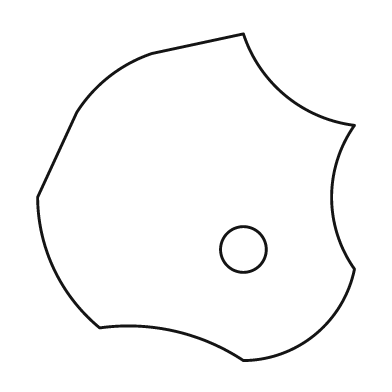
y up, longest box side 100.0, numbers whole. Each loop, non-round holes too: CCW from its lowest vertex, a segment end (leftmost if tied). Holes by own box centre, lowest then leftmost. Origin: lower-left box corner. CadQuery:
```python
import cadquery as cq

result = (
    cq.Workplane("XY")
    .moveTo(63.0, 0.0)
    .threePointArc((85.0, 8.0), (97.0, 28.0))
    .threePointArc((90.0, 50.0), (97.0, 72.0))
    .threePointArc((76.0, 81.0), (63.0, 100.0))
    .lineTo(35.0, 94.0)
    .threePointArc((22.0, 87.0), (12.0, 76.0))
    .lineTo(0.0, 50.0)
    .threePointArc((5.0, 28.0), (19.0, 10.0))
    .threePointArc((42.0, 9.0), (63.0, 0.0))
    .close()
    .moveTo(63.0, 34.0)
    .circle(7.0)
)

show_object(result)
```